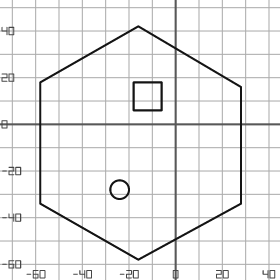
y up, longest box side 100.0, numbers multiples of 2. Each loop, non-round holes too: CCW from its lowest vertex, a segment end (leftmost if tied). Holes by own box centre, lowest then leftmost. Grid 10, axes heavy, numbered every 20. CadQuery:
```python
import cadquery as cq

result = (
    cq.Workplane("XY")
    .moveTo(-16.0, -58.0)
    .lineTo(28.0, -34.0)
    .lineTo(28.0, 16.0)
    .lineTo(-16.0, 42.0)
    .lineTo(-58.0, 18.0)
    .lineTo(-58.0, -34.0)
    .close()
    .moveTo(-24.0, -28.0)
    .circle(4.0)
    .moveTo(-18.0, 6.0)
    .lineTo(-6.0, 6.0)
    .lineTo(-6.0, 18.0)
    .lineTo(-18.0, 18.0)
    .close()
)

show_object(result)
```